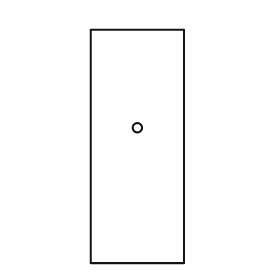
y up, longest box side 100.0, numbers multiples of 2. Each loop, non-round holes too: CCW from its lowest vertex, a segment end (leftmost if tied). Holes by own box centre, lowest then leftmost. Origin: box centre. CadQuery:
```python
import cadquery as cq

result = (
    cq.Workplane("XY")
    .moveTo(-20.0, -50.0)
    .lineTo(20.0, -50.0)
    .lineTo(20.0, 50.0)
    .lineTo(-20.0, 50.0)
    .close()
    .moveTo(0.0, 8.0)
    .circle(2.0)
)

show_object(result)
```